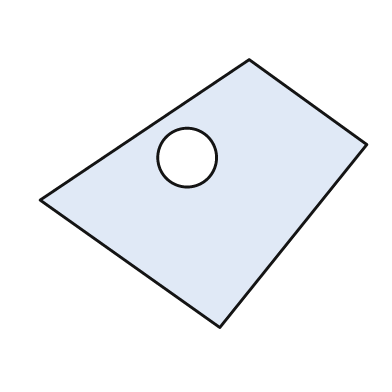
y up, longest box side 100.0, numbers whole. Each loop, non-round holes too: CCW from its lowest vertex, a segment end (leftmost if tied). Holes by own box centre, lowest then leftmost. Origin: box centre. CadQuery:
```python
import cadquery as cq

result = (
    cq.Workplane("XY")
    .moveTo(5.0, -41.0)
    .lineTo(50.0, 15.0)
    .lineTo(14.0, 41.0)
    .lineTo(-50.0, -2.0)
    .close()
    .moveTo(-5.0, 11.0)
    .circle(9.0)
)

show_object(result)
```